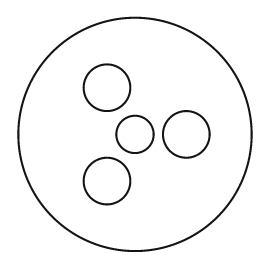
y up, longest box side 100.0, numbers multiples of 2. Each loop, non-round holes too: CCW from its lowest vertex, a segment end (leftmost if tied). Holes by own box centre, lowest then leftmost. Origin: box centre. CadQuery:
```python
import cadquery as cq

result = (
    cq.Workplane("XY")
    .moveTo(0.0, 0.0)
    .circle(50.0)
    .moveTo(-12.0, -20.0)
    .circle(10.0)
    .moveTo(0.0, 0.0)
    .circle(8.0)
    .moveTo(22.0, 0.0)
    .circle(10.0)
    .moveTo(-12.0, 20.0)
    .circle(10.0)
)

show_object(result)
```